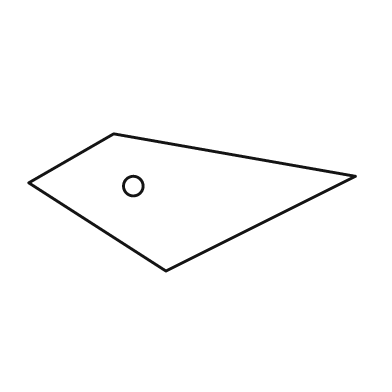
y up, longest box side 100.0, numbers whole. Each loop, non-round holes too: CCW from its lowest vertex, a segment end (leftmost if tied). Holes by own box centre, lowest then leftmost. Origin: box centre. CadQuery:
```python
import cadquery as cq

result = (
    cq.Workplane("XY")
    .moveTo(-8.0, -21.0)
    .lineTo(50.0, 8.0)
    .lineTo(-24.0, 21.0)
    .lineTo(-50.0, 6.0)
    .close()
    .moveTo(-18.0, 5.0)
    .circle(3.0)
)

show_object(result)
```